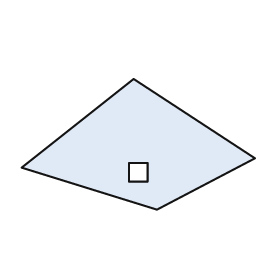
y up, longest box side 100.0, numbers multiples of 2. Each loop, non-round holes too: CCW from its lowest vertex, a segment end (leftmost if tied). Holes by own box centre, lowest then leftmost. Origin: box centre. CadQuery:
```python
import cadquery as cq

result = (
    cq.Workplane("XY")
    .moveTo(8.0, -28.0)
    .lineTo(50.0, -6.0)
    .lineTo(-2.0, 28.0)
    .lineTo(-50.0, -10.0)
    .close()
    .moveTo(-4.0, -16.0)
    .lineTo(4.0, -16.0)
    .lineTo(4.0, -8.0)
    .lineTo(-4.0, -8.0)
    .close()
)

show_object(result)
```